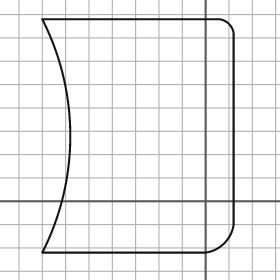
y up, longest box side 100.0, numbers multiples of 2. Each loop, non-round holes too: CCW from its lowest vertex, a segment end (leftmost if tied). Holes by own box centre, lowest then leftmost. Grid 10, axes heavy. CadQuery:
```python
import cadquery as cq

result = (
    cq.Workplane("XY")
    .moveTo(-70.0, -22.0)
    .lineTo(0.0, -22.0)
    .threePointArc((8.0, -18.0), (12.0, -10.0))
    .lineTo(12.0, 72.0)
    .threePointArc((10.0, 76.0), (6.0, 78.0))
    .lineTo(-70.0, 78.0)
    .threePointArc((-58.0, 28.0), (-70.0, -22.0))
    .close()
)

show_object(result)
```